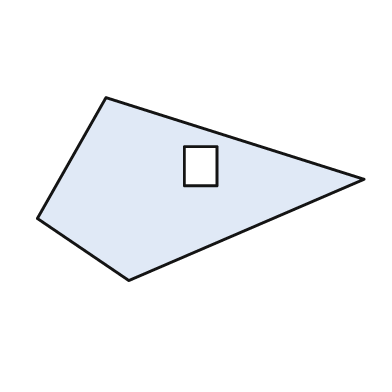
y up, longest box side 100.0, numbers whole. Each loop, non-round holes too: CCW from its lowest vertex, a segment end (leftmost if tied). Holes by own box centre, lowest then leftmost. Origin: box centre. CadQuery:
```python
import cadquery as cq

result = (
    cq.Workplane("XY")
    .moveTo(-22.0, -28.0)
    .lineTo(50.0, 3.0)
    .lineTo(-29.0, 28.0)
    .lineTo(-50.0, -9.0)
    .close()
    .moveTo(-5.0, 1.0)
    .lineTo(5.0, 1.0)
    .lineTo(5.0, 13.0)
    .lineTo(-5.0, 13.0)
    .close()
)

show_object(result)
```